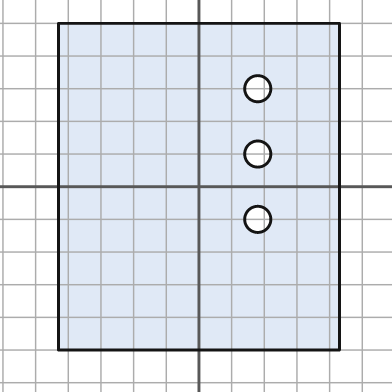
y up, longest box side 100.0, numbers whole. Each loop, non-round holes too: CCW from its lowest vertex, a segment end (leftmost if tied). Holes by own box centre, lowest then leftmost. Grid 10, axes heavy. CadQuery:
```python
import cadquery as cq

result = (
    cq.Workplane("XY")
    .moveTo(-43.0, -50.0)
    .lineTo(43.0, -50.0)
    .lineTo(43.0, 50.0)
    .lineTo(-43.0, 50.0)
    .close()
    .moveTo(18.0, -10.0)
    .circle(4.0)
    .moveTo(18.0, 10.0)
    .circle(4.0)
    .moveTo(18.0, 30.0)
    .circle(4.0)
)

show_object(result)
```